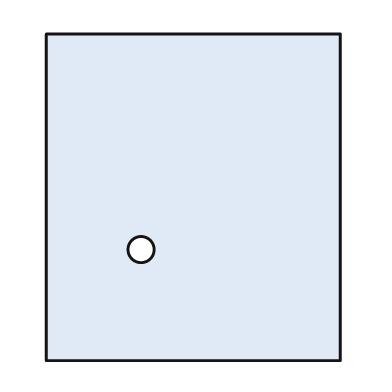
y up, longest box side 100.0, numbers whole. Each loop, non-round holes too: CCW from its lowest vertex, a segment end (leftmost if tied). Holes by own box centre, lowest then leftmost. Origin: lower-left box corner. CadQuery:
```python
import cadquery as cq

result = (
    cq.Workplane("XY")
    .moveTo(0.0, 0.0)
    .lineTo(90.0, 0.0)
    .lineTo(90.0, 100.0)
    .lineTo(0.0, 100.0)
    .close()
    .moveTo(29.0, 34.0)
    .circle(4.0)
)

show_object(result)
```